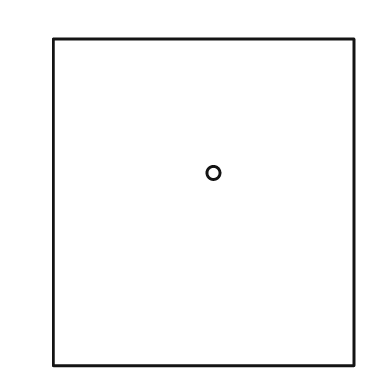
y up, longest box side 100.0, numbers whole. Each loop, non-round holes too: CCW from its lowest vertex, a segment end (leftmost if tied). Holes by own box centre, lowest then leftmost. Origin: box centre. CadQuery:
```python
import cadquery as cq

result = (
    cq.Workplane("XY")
    .moveTo(-46.0, -50.0)
    .lineTo(46.0, -50.0)
    .lineTo(46.0, 50.0)
    .lineTo(-46.0, 50.0)
    .close()
    .moveTo(3.0, 9.0)
    .circle(2.0)
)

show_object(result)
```